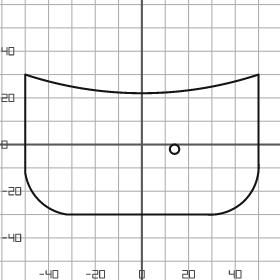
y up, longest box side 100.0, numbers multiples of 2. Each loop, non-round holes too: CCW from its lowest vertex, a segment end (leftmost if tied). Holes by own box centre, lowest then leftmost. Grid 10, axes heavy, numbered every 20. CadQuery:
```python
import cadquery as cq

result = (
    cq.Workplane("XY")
    .moveTo(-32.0, -30.0)
    .lineTo(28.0, -30.0)
    .threePointArc((44.0, -24.0), (50.0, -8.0))
    .lineTo(50.0, 30.0)
    .threePointArc((0.0, 22.0), (-50.0, 30.0))
    .lineTo(-50.0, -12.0)
    .threePointArc((-44.0, -24.0), (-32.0, -30.0))
    .close()
    .moveTo(14.0, -2.0)
    .circle(2.0)
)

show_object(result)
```